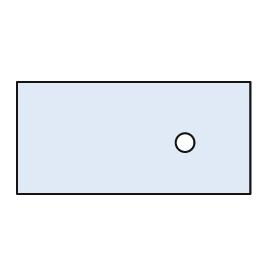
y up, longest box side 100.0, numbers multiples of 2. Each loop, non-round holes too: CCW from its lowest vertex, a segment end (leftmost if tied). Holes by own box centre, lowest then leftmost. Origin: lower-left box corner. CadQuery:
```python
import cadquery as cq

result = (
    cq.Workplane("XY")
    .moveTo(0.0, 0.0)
    .lineTo(100.0, 0.0)
    .lineTo(100.0, 48.0)
    .lineTo(0.0, 48.0)
    .close()
    .moveTo(72.0, 22.0)
    .circle(4.0)
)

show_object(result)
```